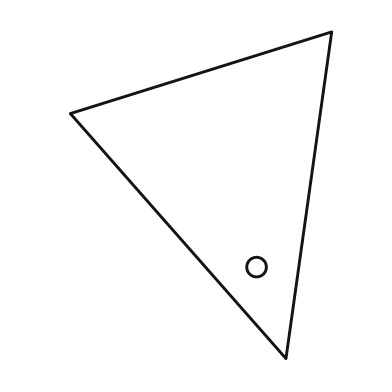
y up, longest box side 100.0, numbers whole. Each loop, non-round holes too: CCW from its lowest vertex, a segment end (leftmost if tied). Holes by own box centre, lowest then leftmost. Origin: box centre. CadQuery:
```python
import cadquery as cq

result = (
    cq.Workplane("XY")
    .moveTo(26.0, -50.0)
    .lineTo(40.0, 50.0)
    .lineTo(-40.0, 25.0)
    .close()
    .moveTo(17.0, -22.0)
    .circle(3.0)
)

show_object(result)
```